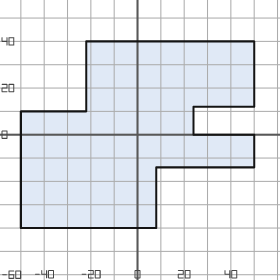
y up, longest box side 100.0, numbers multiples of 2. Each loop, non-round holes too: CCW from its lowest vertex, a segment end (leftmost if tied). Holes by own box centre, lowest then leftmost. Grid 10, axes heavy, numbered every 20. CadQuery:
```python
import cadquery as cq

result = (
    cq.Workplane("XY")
    .moveTo(-50.0, -40.0)
    .lineTo(8.0, -40.0)
    .lineTo(8.0, -14.0)
    .lineTo(50.0, -14.0)
    .lineTo(50.0, 0.0)
    .lineTo(24.0, 0.0)
    .lineTo(24.0, 12.0)
    .lineTo(50.0, 12.0)
    .lineTo(50.0, 40.0)
    .lineTo(-22.0, 40.0)
    .lineTo(-22.0, 10.0)
    .lineTo(-50.0, 10.0)
    .close()
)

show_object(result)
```